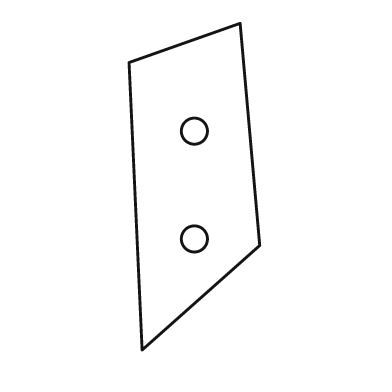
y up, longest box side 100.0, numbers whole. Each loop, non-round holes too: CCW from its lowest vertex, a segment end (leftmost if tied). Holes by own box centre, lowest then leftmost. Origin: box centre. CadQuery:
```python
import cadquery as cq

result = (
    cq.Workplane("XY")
    .moveTo(-16.0, -50.0)
    .lineTo(20.0, -18.0)
    .lineTo(14.0, 50.0)
    .lineTo(-20.0, 38.0)
    .close()
    .moveTo(0.0, -16.0)
    .circle(4.0)
    .moveTo(0.0, 17.0)
    .circle(4.0)
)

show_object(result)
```